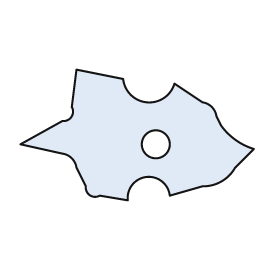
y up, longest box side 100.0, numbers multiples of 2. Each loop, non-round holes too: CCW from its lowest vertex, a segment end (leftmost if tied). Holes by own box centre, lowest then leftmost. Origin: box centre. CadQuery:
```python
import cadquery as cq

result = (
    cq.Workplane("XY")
    .moveTo(-4.0, -28.0)
    .threePointArc((4.0, -18.0), (14.0, -26.0))
    .lineTo(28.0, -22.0)
    .threePointArc((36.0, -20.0), (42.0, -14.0))
    .lineTo(50.0, -6.0)
    .threePointArc((42.0, -2.0), (36.0, 4.0))
    .lineTo(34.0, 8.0)
    .threePointArc((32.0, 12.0), (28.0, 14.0))
    .lineTo(16.0, 22.0)
    .threePointArc((4.0, 14.0), (-6.0, 24.0))
    .lineTo(-26.0, 28.0)
    .lineTo(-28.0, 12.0)
    .threePointArc((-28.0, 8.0), (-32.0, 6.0))
    .lineTo(-50.0, -4.0)
    .lineTo(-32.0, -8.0)
    .threePointArc((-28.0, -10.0), (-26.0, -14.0))
    .lineTo(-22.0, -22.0)
    .threePointArc((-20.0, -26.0), (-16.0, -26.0))
    .close()
    .moveTo(8.0, -4.0)
    .circle(6.0)
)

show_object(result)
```